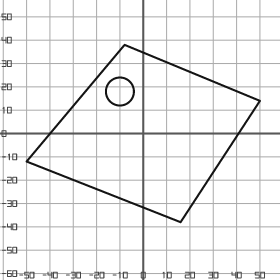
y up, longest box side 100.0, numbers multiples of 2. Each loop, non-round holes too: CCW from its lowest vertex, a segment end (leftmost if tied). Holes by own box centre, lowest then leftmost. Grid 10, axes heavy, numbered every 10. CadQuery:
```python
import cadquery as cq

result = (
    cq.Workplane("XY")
    .moveTo(16.0, -38.0)
    .lineTo(50.0, 14.0)
    .lineTo(-8.0, 38.0)
    .lineTo(-50.0, -12.0)
    .close()
    .moveTo(-10.0, 18.0)
    .circle(6.0)
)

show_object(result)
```